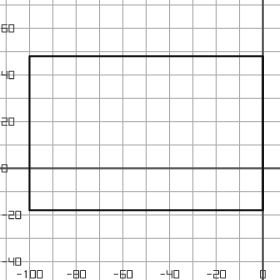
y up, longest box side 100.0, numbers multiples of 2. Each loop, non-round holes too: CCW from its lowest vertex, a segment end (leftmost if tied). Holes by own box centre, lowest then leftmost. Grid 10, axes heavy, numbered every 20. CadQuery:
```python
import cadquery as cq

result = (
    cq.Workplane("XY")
    .moveTo(-100.0, -18.0)
    .lineTo(0.0, -18.0)
    .lineTo(0.0, 48.0)
    .lineTo(-100.0, 48.0)
    .close()
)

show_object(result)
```